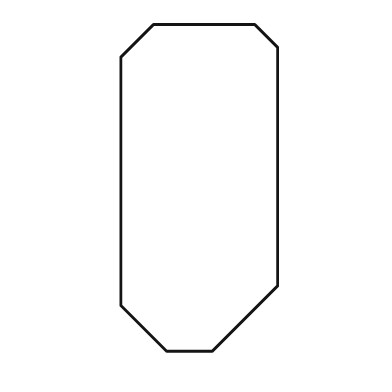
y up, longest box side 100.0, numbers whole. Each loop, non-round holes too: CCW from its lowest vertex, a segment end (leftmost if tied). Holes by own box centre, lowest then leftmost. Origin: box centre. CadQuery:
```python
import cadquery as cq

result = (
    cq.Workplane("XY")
    .moveTo(-10.0, -50.0)
    .lineTo(4.0, -50.0)
    .lineTo(24.0, -30.0)
    .lineTo(24.0, 43.0)
    .lineTo(17.0, 50.0)
    .lineTo(-14.0, 50.0)
    .lineTo(-24.0, 40.0)
    .lineTo(-24.0, -36.0)
    .close()
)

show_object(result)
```